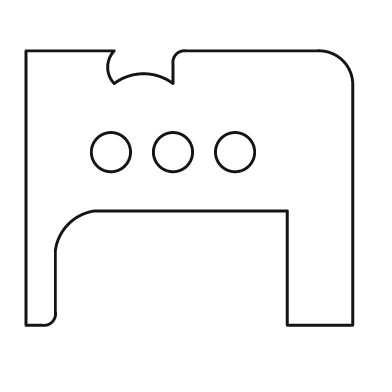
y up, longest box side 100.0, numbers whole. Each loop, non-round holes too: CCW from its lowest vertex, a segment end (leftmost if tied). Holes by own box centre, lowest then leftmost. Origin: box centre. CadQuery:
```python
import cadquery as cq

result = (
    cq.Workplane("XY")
    .moveTo(-50.0, -42.0)
    .lineTo(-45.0, -42.0)
    .threePointArc((-42.0, -41.0), (-41.0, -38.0))
    .lineTo(-41.0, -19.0)
    .threePointArc((-37.0, -11.0), (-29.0, -7.0))
    .lineTo(30.0, -7.0)
    .lineTo(30.0, -42.0)
    .lineTo(50.0, -42.0)
    .lineTo(50.0, 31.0)
    .threePointArc((47.0, 39.0), (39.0, 42.0))
    .lineTo(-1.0, 42.0)
    .threePointArc((-4.0, 41.0), (-5.0, 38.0))
    .lineTo(-5.0, 32.0)
    .threePointArc((-14.0, 35.0), (-23.0, 32.0))
    .threePointArc((-25.0, 37.0), (-23.0, 42.0))
    .lineTo(-50.0, 42.0)
    .close()
    .moveTo(-24.0, 11.0)
    .circle(6.0)
    .moveTo(-5.0, 11.0)
    .circle(6.0)
    .moveTo(14.0, 11.0)
    .circle(6.0)
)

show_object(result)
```